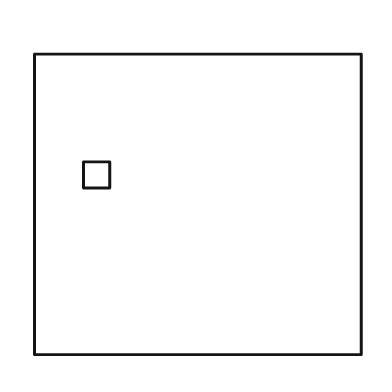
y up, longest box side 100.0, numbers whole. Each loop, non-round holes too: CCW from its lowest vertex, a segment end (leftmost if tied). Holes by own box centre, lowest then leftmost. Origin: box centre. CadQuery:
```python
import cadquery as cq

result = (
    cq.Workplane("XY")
    .moveTo(-50.0, -46.0)
    .lineTo(50.0, -46.0)
    .lineTo(50.0, 46.0)
    .lineTo(-50.0, 46.0)
    .close()
    .moveTo(-35.0, 5.0)
    .lineTo(-27.0, 5.0)
    .lineTo(-27.0, 13.0)
    .lineTo(-35.0, 13.0)
    .close()
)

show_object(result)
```